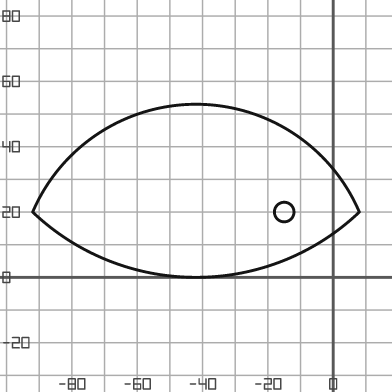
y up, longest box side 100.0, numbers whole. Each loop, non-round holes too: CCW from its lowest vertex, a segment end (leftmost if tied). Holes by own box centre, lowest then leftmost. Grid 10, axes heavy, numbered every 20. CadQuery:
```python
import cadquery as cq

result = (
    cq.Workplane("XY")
    .moveTo(-92.0, 20.0)
    .threePointArc((-42.0, 0.0), (8.0, 20.0))
    .threePointArc((-42.0, 53.0), (-92.0, 20.0))
    .close()
    .moveTo(-15.0, 20.0)
    .circle(3.0)
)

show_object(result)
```